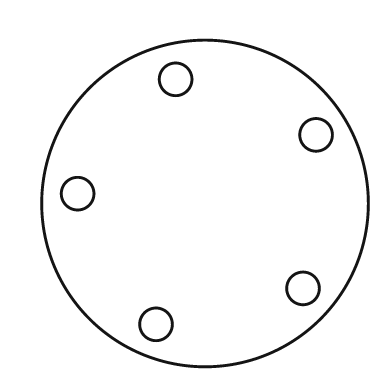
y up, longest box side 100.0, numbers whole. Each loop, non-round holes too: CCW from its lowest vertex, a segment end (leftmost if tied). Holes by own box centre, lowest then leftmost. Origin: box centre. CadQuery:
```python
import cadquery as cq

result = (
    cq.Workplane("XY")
    .moveTo(0.0, 0.0)
    .circle(50.0)
    .moveTo(-15.0, -37.0)
    .circle(5.0)
    .moveTo(30.0, -26.0)
    .circle(5.0)
    .moveTo(-39.0, 3.0)
    .circle(5.0)
    .moveTo(34.0, 21.0)
    .circle(5.0)
    .moveTo(-9.0, 38.0)
    .circle(5.0)
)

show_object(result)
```